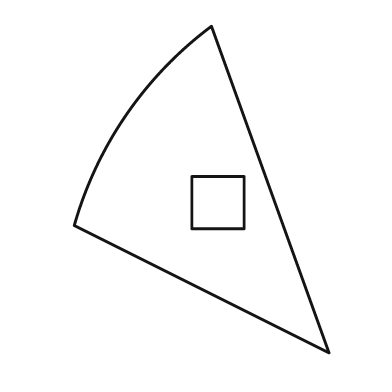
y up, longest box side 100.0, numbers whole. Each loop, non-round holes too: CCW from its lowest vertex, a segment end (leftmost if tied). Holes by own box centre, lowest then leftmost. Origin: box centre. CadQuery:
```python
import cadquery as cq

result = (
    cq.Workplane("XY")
    .moveTo(39.0, -50.0)
    .lineTo(3.0, 50.0)
    .threePointArc((-23.0, 23.0), (-39.0, -11.0))
    .close()
    .moveTo(-3.0, -12.0)
    .lineTo(13.0, -12.0)
    .lineTo(13.0, 4.0)
    .lineTo(-3.0, 4.0)
    .close()
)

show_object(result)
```